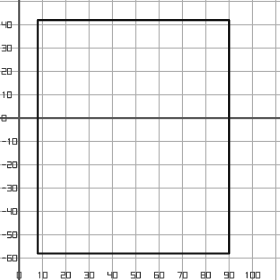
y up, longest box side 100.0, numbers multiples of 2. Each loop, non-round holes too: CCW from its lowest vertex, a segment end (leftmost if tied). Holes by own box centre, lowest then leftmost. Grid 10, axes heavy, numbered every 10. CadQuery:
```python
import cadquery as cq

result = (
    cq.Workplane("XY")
    .moveTo(8.0, -58.0)
    .lineTo(90.0, -58.0)
    .lineTo(90.0, 42.0)
    .lineTo(8.0, 42.0)
    .close()
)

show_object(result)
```